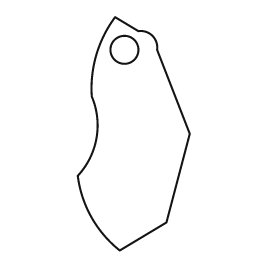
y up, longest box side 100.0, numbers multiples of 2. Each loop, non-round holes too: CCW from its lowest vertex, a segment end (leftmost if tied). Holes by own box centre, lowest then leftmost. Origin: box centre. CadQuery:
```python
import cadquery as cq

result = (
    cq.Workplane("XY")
    .moveTo(-6.0, -50.0)
    .lineTo(14.0, -38.0)
    .lineTo(24.0, 0.0)
    .lineTo(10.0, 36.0)
    .threePointArc((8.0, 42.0), (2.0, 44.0))
    .lineTo(-8.0, 50.0)
    .threePointArc((-16.0, 34.0), (-18.0, 16.0))
    .threePointArc((-16.0, -2.0), (-24.0, -18.0))
    .threePointArc((-18.0, -36.0), (-6.0, -50.0))
    .close()
    .moveTo(-4.0, 36.0)
    .circle(6.0)
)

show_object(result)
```